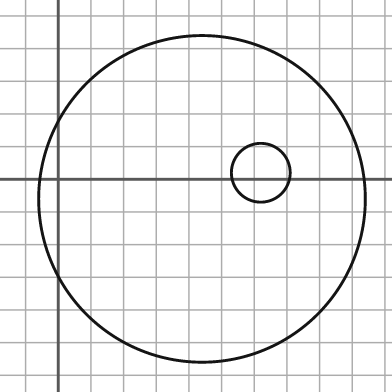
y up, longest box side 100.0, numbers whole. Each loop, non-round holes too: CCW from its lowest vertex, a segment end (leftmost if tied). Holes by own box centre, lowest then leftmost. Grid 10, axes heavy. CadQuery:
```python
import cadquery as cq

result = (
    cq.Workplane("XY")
    .moveTo(44.0, -6.0)
    .circle(50.0)
    .moveTo(62.0, 2.0)
    .circle(9.0)
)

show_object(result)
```